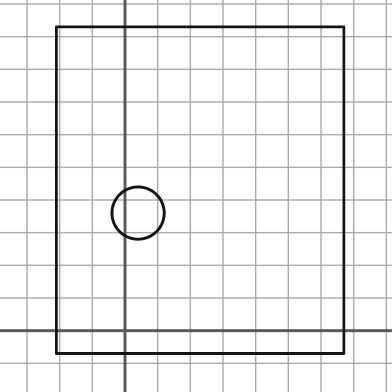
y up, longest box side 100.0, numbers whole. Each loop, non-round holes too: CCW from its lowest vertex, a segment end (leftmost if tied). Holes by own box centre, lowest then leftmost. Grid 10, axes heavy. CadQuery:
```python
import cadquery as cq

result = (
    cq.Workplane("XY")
    .moveTo(-21.0, -7.0)
    .lineTo(67.0, -7.0)
    .lineTo(67.0, 93.0)
    .lineTo(-21.0, 93.0)
    .close()
    .moveTo(4.0, 36.0)
    .circle(8.0)
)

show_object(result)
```